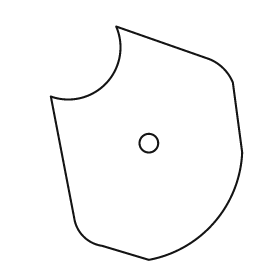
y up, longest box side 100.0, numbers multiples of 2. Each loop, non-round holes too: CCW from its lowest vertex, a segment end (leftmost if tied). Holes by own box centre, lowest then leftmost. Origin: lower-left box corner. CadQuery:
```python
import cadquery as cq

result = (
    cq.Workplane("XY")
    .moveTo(42.0, 0.0)
    .threePointArc((70.0, 16.0), (82.0, 46.0))
    .lineTo(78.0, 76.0)
    .threePointArc((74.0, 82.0), (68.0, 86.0))
    .lineTo(28.0, 100.0)
    .threePointArc((24.0, 76.0), (0.0, 70.0))
    .lineTo(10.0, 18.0)
    .threePointArc((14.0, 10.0), (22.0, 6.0))
    .close()
    .moveTo(42.0, 50.0)
    .circle(4.0)
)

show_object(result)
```